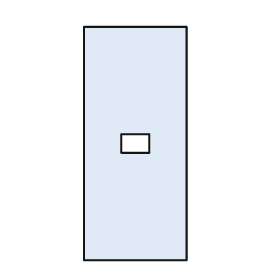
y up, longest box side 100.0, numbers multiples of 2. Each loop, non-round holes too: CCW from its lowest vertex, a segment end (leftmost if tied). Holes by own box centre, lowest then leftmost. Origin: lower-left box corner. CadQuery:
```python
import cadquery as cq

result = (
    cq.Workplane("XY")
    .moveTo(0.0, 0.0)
    .lineTo(44.0, 0.0)
    .lineTo(44.0, 100.0)
    .lineTo(0.0, 100.0)
    .close()
    .moveTo(16.0, 46.0)
    .lineTo(28.0, 46.0)
    .lineTo(28.0, 54.0)
    .lineTo(16.0, 54.0)
    .close()
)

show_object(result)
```